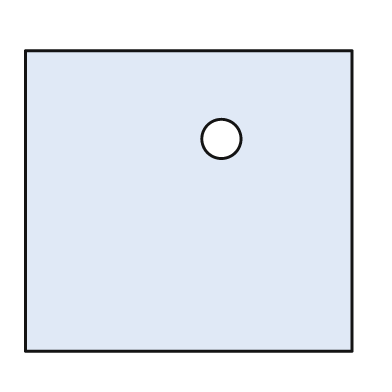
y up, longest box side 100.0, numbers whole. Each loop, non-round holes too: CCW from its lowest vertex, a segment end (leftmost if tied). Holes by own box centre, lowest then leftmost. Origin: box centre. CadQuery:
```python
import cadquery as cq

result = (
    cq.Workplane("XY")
    .moveTo(-50.0, -46.0)
    .lineTo(50.0, -46.0)
    .lineTo(50.0, 46.0)
    .lineTo(-50.0, 46.0)
    .close()
    .moveTo(10.0, 19.0)
    .circle(6.0)
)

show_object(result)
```